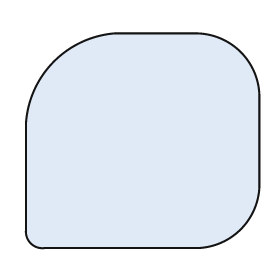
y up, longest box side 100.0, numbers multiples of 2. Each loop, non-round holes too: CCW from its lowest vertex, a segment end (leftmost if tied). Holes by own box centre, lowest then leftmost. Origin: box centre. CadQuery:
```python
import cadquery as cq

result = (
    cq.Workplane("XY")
    .moveTo(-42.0, -46.0)
    .lineTo(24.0, -46.0)
    .threePointArc((42.0, -38.0), (50.0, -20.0))
    .lineTo(50.0, 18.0)
    .threePointArc((42.0, 38.0), (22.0, 46.0))
    .lineTo(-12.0, 46.0)
    .threePointArc((-38.0, 34.0), (-50.0, 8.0))
    .lineTo(-50.0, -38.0)
    .threePointArc((-48.0, -44.0), (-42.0, -46.0))
    .close()
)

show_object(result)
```